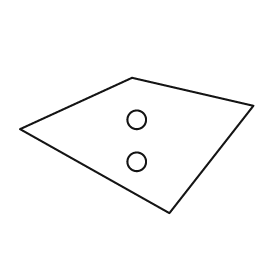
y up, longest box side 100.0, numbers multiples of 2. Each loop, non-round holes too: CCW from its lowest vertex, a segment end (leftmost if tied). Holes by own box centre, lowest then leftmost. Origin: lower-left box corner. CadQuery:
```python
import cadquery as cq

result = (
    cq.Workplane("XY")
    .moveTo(64.0, 0.0)
    .lineTo(100.0, 46.0)
    .lineTo(48.0, 58.0)
    .lineTo(0.0, 36.0)
    .close()
    .moveTo(50.0, 22.0)
    .circle(4.0)
    .moveTo(50.0, 40.0)
    .circle(4.0)
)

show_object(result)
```